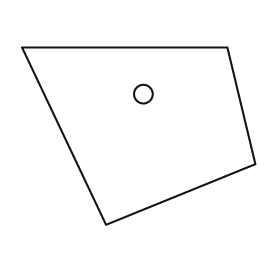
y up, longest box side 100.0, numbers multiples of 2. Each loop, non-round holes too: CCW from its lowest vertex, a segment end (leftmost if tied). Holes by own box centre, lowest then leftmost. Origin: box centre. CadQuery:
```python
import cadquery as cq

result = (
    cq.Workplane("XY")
    .moveTo(-14.0, -38.0)
    .lineTo(50.0, -12.0)
    .lineTo(38.0, 38.0)
    .lineTo(-50.0, 38.0)
    .close()
    .moveTo(2.0, 18.0)
    .circle(4.0)
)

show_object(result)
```